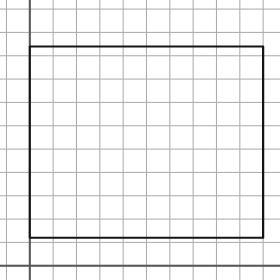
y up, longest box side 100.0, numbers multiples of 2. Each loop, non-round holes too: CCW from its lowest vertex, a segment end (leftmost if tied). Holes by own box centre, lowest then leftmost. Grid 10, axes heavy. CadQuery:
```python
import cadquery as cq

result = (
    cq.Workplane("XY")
    .moveTo(0.0, 12.0)
    .lineTo(100.0, 12.0)
    .lineTo(100.0, 94.0)
    .lineTo(0.0, 94.0)
    .close()
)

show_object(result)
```